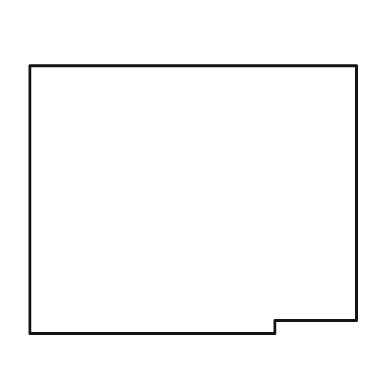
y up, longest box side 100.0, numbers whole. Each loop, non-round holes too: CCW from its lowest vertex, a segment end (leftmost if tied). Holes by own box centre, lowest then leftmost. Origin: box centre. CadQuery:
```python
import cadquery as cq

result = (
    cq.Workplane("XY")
    .moveTo(-50.0, -41.0)
    .lineTo(25.0, -41.0)
    .lineTo(25.0, -37.0)
    .lineTo(50.0, -37.0)
    .lineTo(50.0, 41.0)
    .lineTo(-50.0, 41.0)
    .close()
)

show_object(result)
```